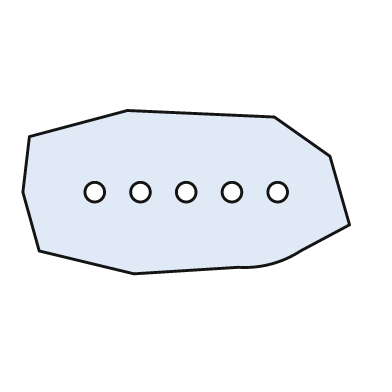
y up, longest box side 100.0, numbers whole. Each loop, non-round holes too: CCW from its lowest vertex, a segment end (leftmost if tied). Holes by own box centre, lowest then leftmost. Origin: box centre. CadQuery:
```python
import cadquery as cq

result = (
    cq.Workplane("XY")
    .moveTo(-16.0, -25.0)
    .lineTo(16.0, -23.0)
    .threePointArc((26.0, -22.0), (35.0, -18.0))
    .lineTo(50.0, -10.0)
    .lineTo(44.0, 11.0)
    .lineTo(27.0, 23.0)
    .lineTo(-18.0, 25.0)
    .lineTo(-48.0, 17.0)
    .lineTo(-50.0, 0.0)
    .lineTo(-45.0, -18.0)
    .close()
    .moveTo(-28.0, 0.0)
    .circle(3.0)
    .moveTo(-14.0, 0.0)
    .circle(3.0)
    .moveTo(0.0, 0.0)
    .circle(3.0)
    .moveTo(14.0, 0.0)
    .circle(3.0)
    .moveTo(28.0, 0.0)
    .circle(3.0)
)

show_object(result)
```